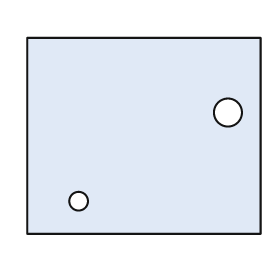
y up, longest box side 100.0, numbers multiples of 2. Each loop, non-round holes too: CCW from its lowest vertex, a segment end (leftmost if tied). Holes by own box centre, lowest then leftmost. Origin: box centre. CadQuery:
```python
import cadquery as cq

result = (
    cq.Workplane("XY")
    .moveTo(-50.0, -42.0)
    .lineTo(50.0, -42.0)
    .lineTo(50.0, 42.0)
    .lineTo(-50.0, 42.0)
    .close()
    .moveTo(-28.0, -28.0)
    .circle(4.0)
    .moveTo(36.0, 10.0)
    .circle(6.0)
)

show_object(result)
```